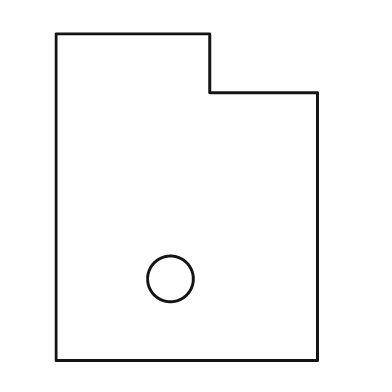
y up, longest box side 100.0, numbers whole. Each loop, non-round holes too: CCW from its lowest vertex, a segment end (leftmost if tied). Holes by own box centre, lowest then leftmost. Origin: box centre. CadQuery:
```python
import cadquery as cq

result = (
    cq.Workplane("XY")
    .moveTo(-40.0, -50.0)
    .lineTo(40.0, -50.0)
    .lineTo(40.0, 32.0)
    .lineTo(7.0, 32.0)
    .lineTo(7.0, 50.0)
    .lineTo(-40.0, 50.0)
    .close()
    .moveTo(-5.0, -25.0)
    .circle(7.0)
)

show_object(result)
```